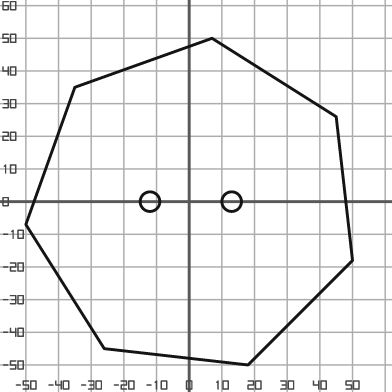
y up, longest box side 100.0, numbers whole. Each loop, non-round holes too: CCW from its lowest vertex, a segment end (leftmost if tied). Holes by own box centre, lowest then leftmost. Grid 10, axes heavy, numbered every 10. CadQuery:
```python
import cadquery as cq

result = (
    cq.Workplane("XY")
    .moveTo(18.0, -50.0)
    .lineTo(50.0, -18.0)
    .lineTo(45.0, 26.0)
    .lineTo(7.0, 50.0)
    .lineTo(-35.0, 35.0)
    .lineTo(-50.0, -7.0)
    .lineTo(-26.0, -45.0)
    .close()
    .moveTo(-12.0, 0.0)
    .circle(3.0)
    .moveTo(13.0, 0.0)
    .circle(3.0)
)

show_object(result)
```